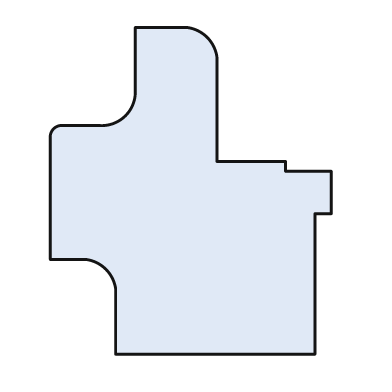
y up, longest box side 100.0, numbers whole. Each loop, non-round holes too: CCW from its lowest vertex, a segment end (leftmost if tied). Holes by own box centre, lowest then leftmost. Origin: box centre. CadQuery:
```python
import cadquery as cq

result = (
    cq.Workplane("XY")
    .moveTo(-23.0, -50.0)
    .lineTo(38.0, -50.0)
    .lineTo(38.0, -7.0)
    .lineTo(43.0, -7.0)
    .lineTo(43.0, 6.0)
    .lineTo(29.0, 6.0)
    .lineTo(29.0, 9.0)
    .lineTo(8.0, 9.0)
    .lineTo(8.0, 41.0)
    .threePointArc((5.0, 47.0), (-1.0, 50.0))
    .lineTo(-17.0, 50.0)
    .lineTo(-17.0, 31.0)
    .threePointArc((-20.0, 23.0), (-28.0, 20.0))
    .lineTo(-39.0, 20.0)
    .threePointArc((-42.0, 19.0), (-43.0, 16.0))
    .lineTo(-43.0, -21.0)
    .lineTo(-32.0, -21.0)
    .threePointArc((-26.0, -24.0), (-23.0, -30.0))
    .close()
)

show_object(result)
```